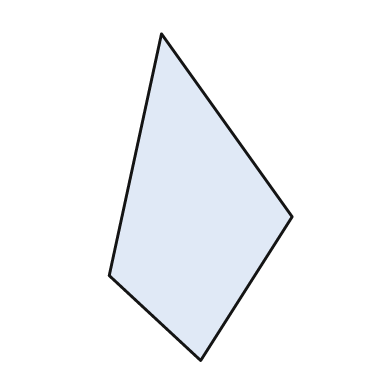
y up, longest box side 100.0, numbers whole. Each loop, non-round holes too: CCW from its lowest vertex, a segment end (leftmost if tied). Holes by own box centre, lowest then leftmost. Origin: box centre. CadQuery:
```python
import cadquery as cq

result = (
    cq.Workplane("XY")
    .moveTo(0.0, -50.0)
    .lineTo(28.0, -6.0)
    .lineTo(-12.0, 50.0)
    .lineTo(-28.0, -24.0)
    .close()
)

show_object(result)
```